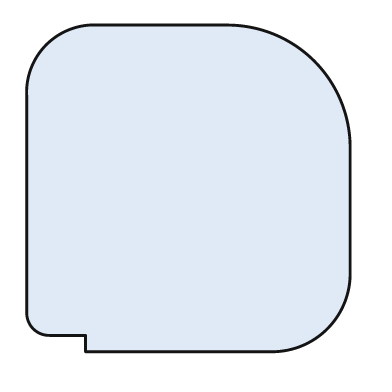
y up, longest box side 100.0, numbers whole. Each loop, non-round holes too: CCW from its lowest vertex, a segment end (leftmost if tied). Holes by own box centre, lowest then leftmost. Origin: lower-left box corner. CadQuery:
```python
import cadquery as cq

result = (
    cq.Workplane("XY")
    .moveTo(18.0, 0.0)
    .lineTo(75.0, 0.0)
    .threePointArc((92.0, 7.0), (99.0, 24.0))
    .lineTo(99.0, 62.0)
    .threePointArc((88.0, 89.0), (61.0, 100.0))
    .lineTo(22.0, 100.0)
    .threePointArc((6.0, 94.0), (0.0, 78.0))
    .lineTo(0.0, 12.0)
    .threePointArc((2.0, 7.0), (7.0, 5.0))
    .lineTo(18.0, 5.0)
    .close()
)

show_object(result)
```